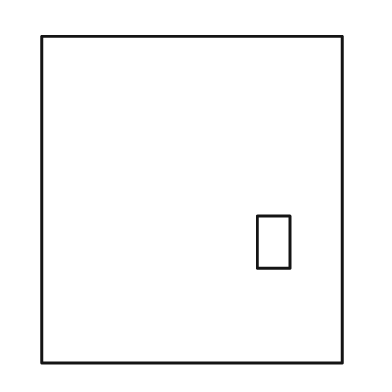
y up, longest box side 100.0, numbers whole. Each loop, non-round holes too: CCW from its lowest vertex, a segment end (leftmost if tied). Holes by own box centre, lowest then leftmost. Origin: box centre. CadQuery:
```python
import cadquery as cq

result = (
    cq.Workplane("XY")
    .moveTo(-46.0, -50.0)
    .lineTo(46.0, -50.0)
    .lineTo(46.0, 50.0)
    .lineTo(-46.0, 50.0)
    .close()
    .moveTo(20.0, -21.0)
    .lineTo(30.0, -21.0)
    .lineTo(30.0, -5.0)
    .lineTo(20.0, -5.0)
    .close()
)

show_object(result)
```